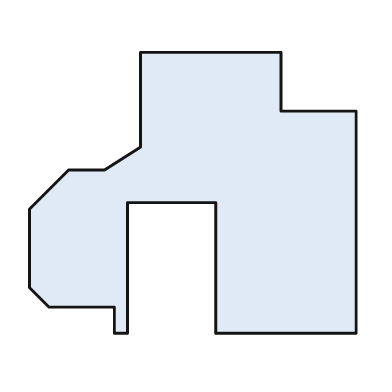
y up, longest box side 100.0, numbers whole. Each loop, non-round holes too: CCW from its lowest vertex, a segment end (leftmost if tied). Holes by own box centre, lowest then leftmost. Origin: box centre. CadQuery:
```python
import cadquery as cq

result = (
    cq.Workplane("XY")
    .moveTo(-24.0, -43.0)
    .lineTo(-20.0, -43.0)
    .lineTo(-20.0, -3.0)
    .lineTo(7.0, -3.0)
    .lineTo(7.0, -43.0)
    .lineTo(50.0, -43.0)
    .lineTo(50.0, 25.0)
    .lineTo(27.0, 25.0)
    .lineTo(27.0, 43.0)
    .lineTo(-16.0, 43.0)
    .lineTo(-16.0, 14.0)
    .lineTo(-27.0, 7.0)
    .lineTo(-38.0, 7.0)
    .lineTo(-50.0, -5.0)
    .lineTo(-50.0, -29.0)
    .lineTo(-44.0, -35.0)
    .lineTo(-24.0, -35.0)
    .close()
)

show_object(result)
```